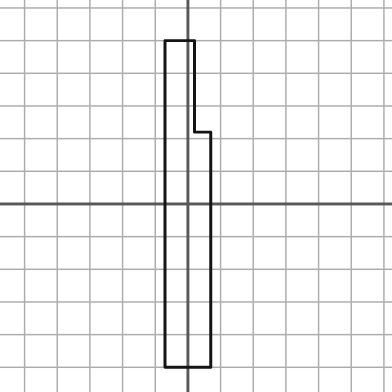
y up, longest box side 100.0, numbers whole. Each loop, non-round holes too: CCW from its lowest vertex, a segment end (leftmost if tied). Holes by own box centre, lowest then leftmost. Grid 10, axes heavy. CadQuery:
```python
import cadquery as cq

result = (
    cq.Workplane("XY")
    .moveTo(-7.0, -50.0)
    .lineTo(7.0, -50.0)
    .lineTo(7.0, 22.0)
    .lineTo(2.0, 22.0)
    .lineTo(2.0, 50.0)
    .lineTo(-7.0, 50.0)
    .close()
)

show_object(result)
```